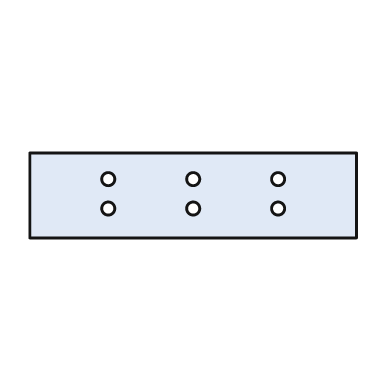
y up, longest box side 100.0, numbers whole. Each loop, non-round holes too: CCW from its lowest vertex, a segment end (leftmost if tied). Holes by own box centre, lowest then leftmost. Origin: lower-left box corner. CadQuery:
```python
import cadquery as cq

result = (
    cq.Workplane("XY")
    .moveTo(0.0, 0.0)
    .lineTo(100.0, 0.0)
    .lineTo(100.0, 26.0)
    .lineTo(0.0, 26.0)
    .close()
    .moveTo(24.0, 9.0)
    .circle(2.0)
    .moveTo(50.0, 9.0)
    .circle(2.0)
    .moveTo(76.0, 9.0)
    .circle(2.0)
    .moveTo(24.0, 18.0)
    .circle(2.0)
    .moveTo(50.0, 18.0)
    .circle(2.0)
    .moveTo(76.0, 18.0)
    .circle(2.0)
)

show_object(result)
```